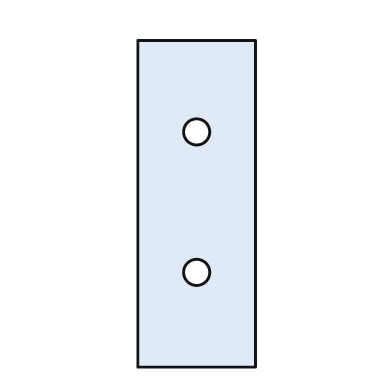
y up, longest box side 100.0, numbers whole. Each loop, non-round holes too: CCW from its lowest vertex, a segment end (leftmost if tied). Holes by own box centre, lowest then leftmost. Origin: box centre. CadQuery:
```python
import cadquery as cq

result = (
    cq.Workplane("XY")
    .moveTo(-18.0, -50.0)
    .lineTo(18.0, -50.0)
    .lineTo(18.0, 50.0)
    .lineTo(-18.0, 50.0)
    .close()
    .moveTo(0.0, -21.0)
    .circle(4.0)
    .moveTo(0.0, 22.0)
    .circle(4.0)
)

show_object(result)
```